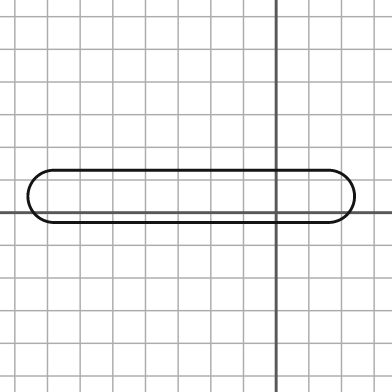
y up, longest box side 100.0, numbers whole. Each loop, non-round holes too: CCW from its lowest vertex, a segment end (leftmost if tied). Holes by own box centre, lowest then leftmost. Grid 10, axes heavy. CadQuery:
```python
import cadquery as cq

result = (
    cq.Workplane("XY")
    .moveTo(-68.0, -3.0)
    .lineTo(16.0, -3.0)
    .threePointArc((24.0, 5.0), (16.0, 13.0))
    .lineTo(-68.0, 13.0)
    .threePointArc((-76.0, 5.0), (-68.0, -3.0))
    .close()
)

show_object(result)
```